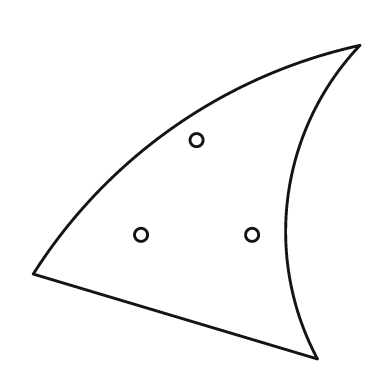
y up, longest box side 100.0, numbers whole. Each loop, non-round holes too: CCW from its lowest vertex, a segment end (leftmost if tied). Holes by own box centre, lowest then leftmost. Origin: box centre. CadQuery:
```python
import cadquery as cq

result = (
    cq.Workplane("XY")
    .moveTo(37.0, -48.0)
    .threePointArc((28.0, 2.0), (50.0, 48.0))
    .threePointArc((-7.0, 23.0), (-50.0, -22.0))
    .close()
    .moveTo(-17.0, -10.0)
    .circle(2.0)
    .moveTo(17.0, -10.0)
    .circle(2.0)
    .moveTo(0.0, 19.0)
    .circle(2.0)
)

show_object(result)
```